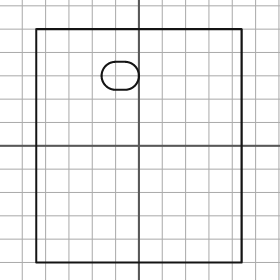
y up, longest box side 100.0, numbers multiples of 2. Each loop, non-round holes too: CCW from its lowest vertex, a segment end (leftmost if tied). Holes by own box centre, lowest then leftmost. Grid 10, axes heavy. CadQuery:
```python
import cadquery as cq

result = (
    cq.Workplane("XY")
    .moveTo(-44.0, -50.0)
    .lineTo(44.0, -50.0)
    .lineTo(44.0, 50.0)
    .lineTo(-44.0, 50.0)
    .close()
    .moveTo(-10.0, 24.0)
    .lineTo(-6.0, 24.0)
    .threePointArc((0.0, 30.0), (-6.0, 36.0))
    .lineTo(-10.0, 36.0)
    .threePointArc((-16.0, 30.0), (-10.0, 24.0))
    .close()
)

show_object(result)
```